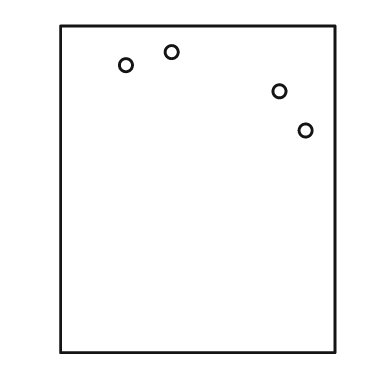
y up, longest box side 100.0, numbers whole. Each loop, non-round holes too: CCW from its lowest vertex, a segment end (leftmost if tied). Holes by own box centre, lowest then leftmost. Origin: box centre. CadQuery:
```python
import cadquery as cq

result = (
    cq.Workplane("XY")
    .moveTo(-42.0, -50.0)
    .lineTo(42.0, -50.0)
    .lineTo(42.0, 50.0)
    .lineTo(-42.0, 50.0)
    .close()
    .moveTo(33.0, 18.0)
    .circle(2.0)
    .moveTo(25.0, 30.0)
    .circle(2.0)
    .moveTo(-22.0, 38.0)
    .circle(2.0)
    .moveTo(-8.0, 42.0)
    .circle(2.0)
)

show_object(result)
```